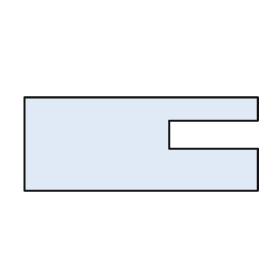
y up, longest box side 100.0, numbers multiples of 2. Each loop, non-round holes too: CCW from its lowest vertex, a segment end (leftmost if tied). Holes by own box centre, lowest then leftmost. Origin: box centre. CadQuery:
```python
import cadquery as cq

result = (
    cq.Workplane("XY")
    .moveTo(-50.0, -20.0)
    .lineTo(50.0, -20.0)
    .lineTo(50.0, -2.0)
    .lineTo(12.0, -2.0)
    .lineTo(12.0, 10.0)
    .lineTo(50.0, 10.0)
    .lineTo(50.0, 20.0)
    .lineTo(-50.0, 20.0)
    .close()
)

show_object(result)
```